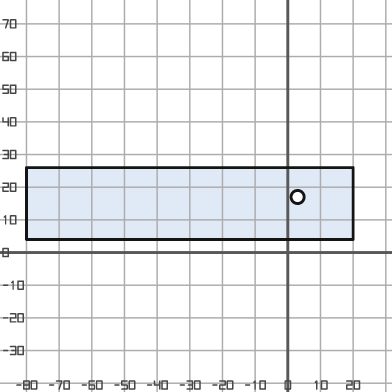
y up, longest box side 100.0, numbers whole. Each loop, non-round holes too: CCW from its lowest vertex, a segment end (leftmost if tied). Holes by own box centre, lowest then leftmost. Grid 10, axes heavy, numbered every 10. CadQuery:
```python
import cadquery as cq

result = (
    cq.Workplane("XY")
    .moveTo(-80.0, 4.0)
    .lineTo(20.0, 4.0)
    .lineTo(20.0, 26.0)
    .lineTo(-80.0, 26.0)
    .close()
    .moveTo(3.0, 17.0)
    .circle(2.0)
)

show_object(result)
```